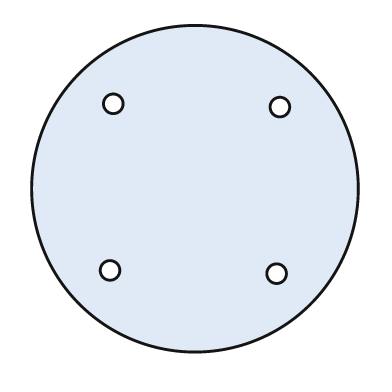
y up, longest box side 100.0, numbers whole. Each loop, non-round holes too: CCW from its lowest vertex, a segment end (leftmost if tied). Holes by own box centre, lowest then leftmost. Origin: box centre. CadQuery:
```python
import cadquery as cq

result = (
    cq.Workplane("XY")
    .moveTo(0.0, 0.0)
    .circle(50.0)
    .moveTo(25.0, -26.0)
    .circle(3.0)
    .moveTo(-26.0, -25.0)
    .circle(3.0)
    .moveTo(26.0, 25.0)
    .circle(3.0)
    .moveTo(-25.0, 26.0)
    .circle(3.0)
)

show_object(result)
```